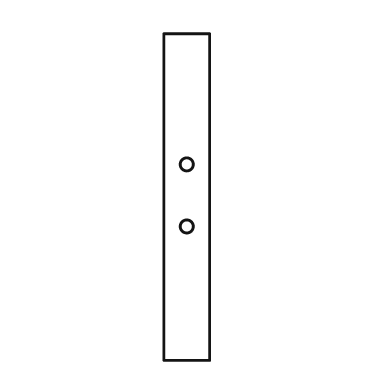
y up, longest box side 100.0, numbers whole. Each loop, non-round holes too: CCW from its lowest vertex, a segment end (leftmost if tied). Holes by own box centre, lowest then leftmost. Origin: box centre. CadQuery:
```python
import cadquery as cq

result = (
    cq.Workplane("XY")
    .moveTo(-7.0, -50.0)
    .lineTo(7.0, -50.0)
    .lineTo(7.0, 50.0)
    .lineTo(-7.0, 50.0)
    .close()
    .moveTo(0.0, -9.0)
    .circle(2.0)
    .moveTo(0.0, 10.0)
    .circle(2.0)
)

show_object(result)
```